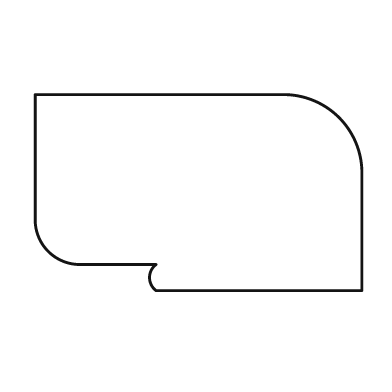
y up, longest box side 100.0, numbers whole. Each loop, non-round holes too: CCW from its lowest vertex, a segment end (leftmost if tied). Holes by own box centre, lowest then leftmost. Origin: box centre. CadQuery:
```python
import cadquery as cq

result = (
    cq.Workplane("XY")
    .moveTo(-13.0, -30.0)
    .lineTo(50.0, -30.0)
    .lineTo(50.0, 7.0)
    .threePointArc((43.0, 23.0), (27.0, 30.0))
    .lineTo(-50.0, 30.0)
    .lineTo(-50.0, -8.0)
    .threePointArc((-46.0, -18.0), (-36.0, -22.0))
    .lineTo(-13.0, -22.0)
    .threePointArc((-15.0, -26.0), (-13.0, -30.0))
    .close()
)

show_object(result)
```